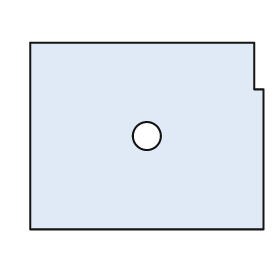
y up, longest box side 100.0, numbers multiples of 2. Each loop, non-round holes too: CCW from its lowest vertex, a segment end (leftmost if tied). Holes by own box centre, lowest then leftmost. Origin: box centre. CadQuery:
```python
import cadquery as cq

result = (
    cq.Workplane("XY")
    .moveTo(-50.0, -40.0)
    .lineTo(50.0, -40.0)
    .lineTo(50.0, 20.0)
    .lineTo(46.0, 20.0)
    .lineTo(46.0, 40.0)
    .lineTo(-50.0, 40.0)
    .close()
    .moveTo(0.0, 0.0)
    .circle(6.0)
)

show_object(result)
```